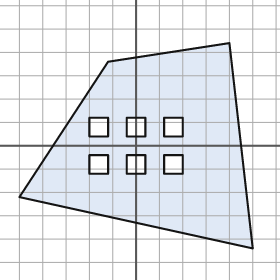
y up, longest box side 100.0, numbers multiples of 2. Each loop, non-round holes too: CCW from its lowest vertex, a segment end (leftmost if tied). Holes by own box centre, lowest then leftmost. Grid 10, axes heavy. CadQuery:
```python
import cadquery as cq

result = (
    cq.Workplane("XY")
    .moveTo(50.0, -44.0)
    .lineTo(40.0, 44.0)
    .lineTo(-12.0, 36.0)
    .lineTo(-50.0, -22.0)
    .close()
    .moveTo(-20.0, -12.0)
    .lineTo(-12.0, -12.0)
    .lineTo(-12.0, -4.0)
    .lineTo(-20.0, -4.0)
    .close()
    .moveTo(-4.0, -12.0)
    .lineTo(4.0, -12.0)
    .lineTo(4.0, -4.0)
    .lineTo(-4.0, -4.0)
    .close()
    .moveTo(12.0, -12.0)
    .lineTo(20.0, -12.0)
    .lineTo(20.0, -4.0)
    .lineTo(12.0, -4.0)
    .close()
    .moveTo(-20.0, 4.0)
    .lineTo(-12.0, 4.0)
    .lineTo(-12.0, 12.0)
    .lineTo(-20.0, 12.0)
    .close()
    .moveTo(-4.0, 4.0)
    .lineTo(4.0, 4.0)
    .lineTo(4.0, 12.0)
    .lineTo(-4.0, 12.0)
    .close()
    .moveTo(12.0, 4.0)
    .lineTo(20.0, 4.0)
    .lineTo(20.0, 12.0)
    .lineTo(12.0, 12.0)
    .close()
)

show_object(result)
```